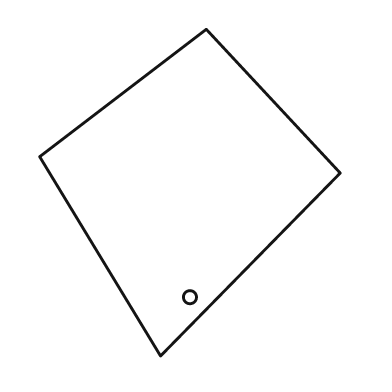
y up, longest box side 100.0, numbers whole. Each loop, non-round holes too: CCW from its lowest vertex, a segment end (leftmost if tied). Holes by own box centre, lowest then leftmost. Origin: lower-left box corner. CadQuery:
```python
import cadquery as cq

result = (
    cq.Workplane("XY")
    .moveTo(37.0, 0.0)
    .lineTo(92.0, 56.0)
    .lineTo(51.0, 100.0)
    .lineTo(0.0, 61.0)
    .close()
    .moveTo(46.0, 18.0)
    .circle(2.0)
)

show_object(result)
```